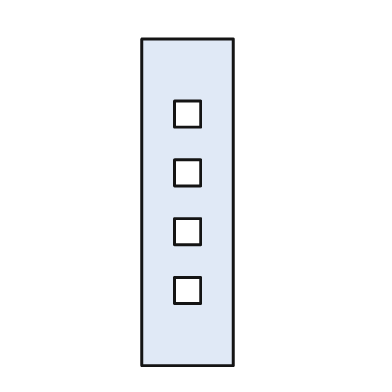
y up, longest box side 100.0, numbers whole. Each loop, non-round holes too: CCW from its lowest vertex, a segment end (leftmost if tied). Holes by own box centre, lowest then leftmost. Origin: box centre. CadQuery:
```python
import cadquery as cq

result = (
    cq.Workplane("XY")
    .moveTo(-14.0, -50.0)
    .lineTo(14.0, -50.0)
    .lineTo(14.0, 50.0)
    .lineTo(-14.0, 50.0)
    .close()
    .moveTo(-4.0, -31.0)
    .lineTo(4.0, -31.0)
    .lineTo(4.0, -23.0)
    .lineTo(-4.0, -23.0)
    .close()
    .moveTo(-4.0, -13.0)
    .lineTo(4.0, -13.0)
    .lineTo(4.0, -5.0)
    .lineTo(-4.0, -5.0)
    .close()
    .moveTo(-4.0, 5.0)
    .lineTo(4.0, 5.0)
    .lineTo(4.0, 13.0)
    .lineTo(-4.0, 13.0)
    .close()
    .moveTo(-4.0, 23.0)
    .lineTo(4.0, 23.0)
    .lineTo(4.0, 31.0)
    .lineTo(-4.0, 31.0)
    .close()
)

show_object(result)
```